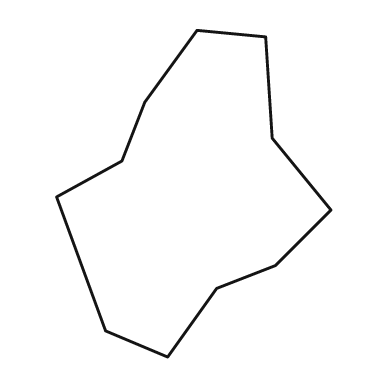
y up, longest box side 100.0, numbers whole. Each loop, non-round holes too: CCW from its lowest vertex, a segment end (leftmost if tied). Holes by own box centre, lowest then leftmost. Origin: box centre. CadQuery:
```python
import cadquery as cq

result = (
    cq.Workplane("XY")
    .moveTo(-8.0, -50.0)
    .lineTo(7.0, -29.0)
    .lineTo(25.0, -22.0)
    .lineTo(42.0, -5.0)
    .lineTo(24.0, 17.0)
    .lineTo(22.0, 48.0)
    .lineTo(1.0, 50.0)
    .lineTo(-15.0, 28.0)
    .lineTo(-22.0, 10.0)
    .lineTo(-42.0, -1.0)
    .lineTo(-27.0, -42.0)
    .close()
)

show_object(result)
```